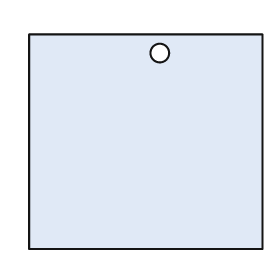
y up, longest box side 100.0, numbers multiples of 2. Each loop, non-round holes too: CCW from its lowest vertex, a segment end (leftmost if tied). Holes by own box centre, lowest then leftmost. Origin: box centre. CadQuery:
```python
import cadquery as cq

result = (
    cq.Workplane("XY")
    .moveTo(-50.0, -46.0)
    .lineTo(50.0, -46.0)
    .lineTo(50.0, 46.0)
    .lineTo(-50.0, 46.0)
    .close()
    .moveTo(6.0, 38.0)
    .circle(4.0)
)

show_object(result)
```